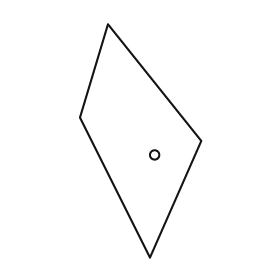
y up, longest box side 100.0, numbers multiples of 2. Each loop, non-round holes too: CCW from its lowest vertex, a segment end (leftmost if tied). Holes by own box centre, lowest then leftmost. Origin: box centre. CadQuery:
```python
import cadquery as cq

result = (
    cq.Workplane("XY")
    .moveTo(4.0, -50.0)
    .lineTo(26.0, 0.0)
    .lineTo(-14.0, 50.0)
    .lineTo(-26.0, 10.0)
    .close()
    .moveTo(6.0, -6.0)
    .circle(2.0)
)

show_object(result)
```